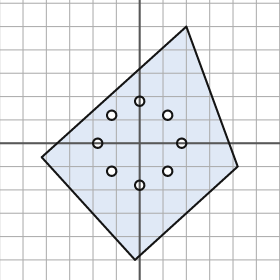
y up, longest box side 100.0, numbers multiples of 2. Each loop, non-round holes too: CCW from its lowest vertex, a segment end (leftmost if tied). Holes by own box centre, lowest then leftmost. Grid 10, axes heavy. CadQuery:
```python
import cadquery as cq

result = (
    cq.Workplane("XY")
    .moveTo(-2.0, -50.0)
    .lineTo(42.0, -10.0)
    .lineTo(20.0, 50.0)
    .lineTo(-42.0, -6.0)
    .close()
    .moveTo(0.0, -18.0)
    .circle(2.0)
    .moveTo(-12.0, -12.0)
    .circle(2.0)
    .moveTo(12.0, -12.0)
    .circle(2.0)
    .moveTo(-18.0, 0.0)
    .circle(2.0)
    .moveTo(18.0, 0.0)
    .circle(2.0)
    .moveTo(-12.0, 12.0)
    .circle(2.0)
    .moveTo(12.0, 12.0)
    .circle(2.0)
    .moveTo(0.0, 18.0)
    .circle(2.0)
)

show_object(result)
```